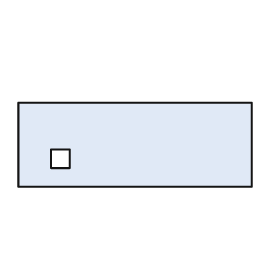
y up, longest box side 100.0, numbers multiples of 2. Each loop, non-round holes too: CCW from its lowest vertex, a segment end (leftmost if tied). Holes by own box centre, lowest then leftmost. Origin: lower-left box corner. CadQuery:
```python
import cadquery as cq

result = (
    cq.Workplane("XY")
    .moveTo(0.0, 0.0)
    .lineTo(100.0, 0.0)
    .lineTo(100.0, 36.0)
    .lineTo(0.0, 36.0)
    .close()
    .moveTo(14.0, 8.0)
    .lineTo(22.0, 8.0)
    .lineTo(22.0, 16.0)
    .lineTo(14.0, 16.0)
    .close()
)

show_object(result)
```